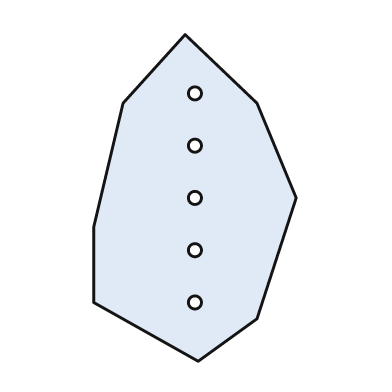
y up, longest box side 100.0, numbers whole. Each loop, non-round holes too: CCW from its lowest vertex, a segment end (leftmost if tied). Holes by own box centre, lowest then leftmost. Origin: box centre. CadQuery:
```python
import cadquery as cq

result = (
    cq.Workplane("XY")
    .moveTo(1.0, -50.0)
    .lineTo(19.0, -37.0)
    .lineTo(31.0, 0.0)
    .lineTo(19.0, 29.0)
    .lineTo(-3.0, 50.0)
    .lineTo(-22.0, 29.0)
    .lineTo(-31.0, -9.0)
    .lineTo(-31.0, -32.0)
    .close()
    .moveTo(0.0, -32.0)
    .circle(2.0)
    .moveTo(0.0, -16.0)
    .circle(2.0)
    .moveTo(0.0, 0.0)
    .circle(2.0)
    .moveTo(0.0, 16.0)
    .circle(2.0)
    .moveTo(0.0, 32.0)
    .circle(2.0)
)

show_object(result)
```